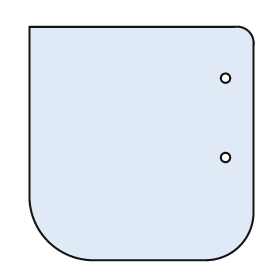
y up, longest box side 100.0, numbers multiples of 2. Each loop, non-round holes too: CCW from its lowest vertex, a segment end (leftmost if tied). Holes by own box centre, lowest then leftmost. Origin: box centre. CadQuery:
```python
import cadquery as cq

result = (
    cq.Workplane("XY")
    .moveTo(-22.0, -50.0)
    .lineTo(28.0, -50.0)
    .threePointArc((42.0, -44.0), (48.0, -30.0))
    .lineTo(48.0, 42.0)
    .threePointArc((46.0, 48.0), (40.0, 50.0))
    .lineTo(-48.0, 50.0)
    .lineTo(-48.0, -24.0)
    .threePointArc((-40.0, -42.0), (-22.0, -50.0))
    .close()
    .moveTo(36.0, -6.0)
    .circle(2.0)
    .moveTo(36.0, 28.0)
    .circle(2.0)
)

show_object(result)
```